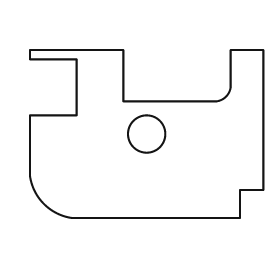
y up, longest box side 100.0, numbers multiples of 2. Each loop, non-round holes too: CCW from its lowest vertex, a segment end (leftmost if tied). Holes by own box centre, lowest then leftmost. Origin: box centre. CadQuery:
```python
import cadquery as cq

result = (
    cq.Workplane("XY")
    .moveTo(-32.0, -36.0)
    .lineTo(40.0, -36.0)
    .lineTo(40.0, -24.0)
    .lineTo(50.0, -24.0)
    .lineTo(50.0, 36.0)
    .lineTo(36.0, 36.0)
    .lineTo(36.0, 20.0)
    .threePointArc((34.0, 16.0), (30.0, 14.0))
    .lineTo(-10.0, 14.0)
    .lineTo(-10.0, 36.0)
    .lineTo(-50.0, 36.0)
    .lineTo(-50.0, 32.0)
    .lineTo(-30.0, 32.0)
    .lineTo(-30.0, 8.0)
    .lineTo(-50.0, 8.0)
    .lineTo(-50.0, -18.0)
    .threePointArc((-44.0, -30.0), (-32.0, -36.0))
    .close()
    .moveTo(0.0, 0.0)
    .circle(8.0)
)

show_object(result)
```